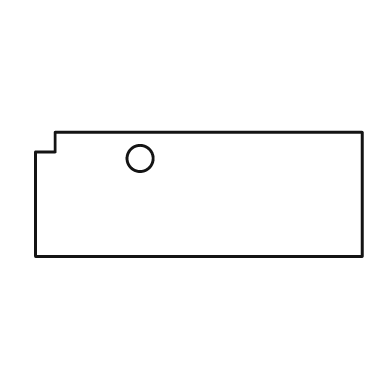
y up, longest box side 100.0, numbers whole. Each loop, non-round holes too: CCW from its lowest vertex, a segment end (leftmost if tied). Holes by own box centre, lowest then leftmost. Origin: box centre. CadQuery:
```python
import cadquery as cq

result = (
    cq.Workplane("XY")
    .moveTo(-50.0, -19.0)
    .lineTo(50.0, -19.0)
    .lineTo(50.0, 19.0)
    .lineTo(-44.0, 19.0)
    .lineTo(-44.0, 13.0)
    .lineTo(-50.0, 13.0)
    .close()
    .moveTo(-18.0, 11.0)
    .circle(4.0)
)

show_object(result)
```